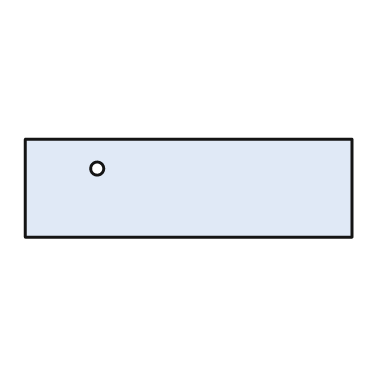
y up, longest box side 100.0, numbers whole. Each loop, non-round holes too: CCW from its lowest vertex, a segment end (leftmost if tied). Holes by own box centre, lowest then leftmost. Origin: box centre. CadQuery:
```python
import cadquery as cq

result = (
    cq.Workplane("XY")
    .moveTo(-50.0, -15.0)
    .lineTo(50.0, -15.0)
    .lineTo(50.0, 15.0)
    .lineTo(-50.0, 15.0)
    .close()
    .moveTo(-28.0, 6.0)
    .circle(2.0)
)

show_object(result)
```